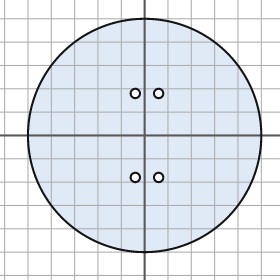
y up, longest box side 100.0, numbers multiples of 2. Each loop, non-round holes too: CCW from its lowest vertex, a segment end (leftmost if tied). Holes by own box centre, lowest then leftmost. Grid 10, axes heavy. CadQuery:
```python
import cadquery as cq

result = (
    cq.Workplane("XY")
    .moveTo(0.0, 0.0)
    .circle(50.0)
    .moveTo(-4.0, -18.0)
    .circle(2.0)
    .moveTo(6.0, -18.0)
    .circle(2.0)
    .moveTo(-4.0, 18.0)
    .circle(2.0)
    .moveTo(6.0, 18.0)
    .circle(2.0)
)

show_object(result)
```